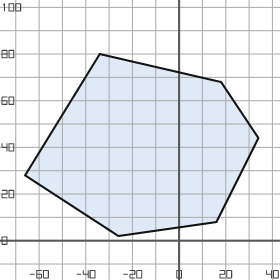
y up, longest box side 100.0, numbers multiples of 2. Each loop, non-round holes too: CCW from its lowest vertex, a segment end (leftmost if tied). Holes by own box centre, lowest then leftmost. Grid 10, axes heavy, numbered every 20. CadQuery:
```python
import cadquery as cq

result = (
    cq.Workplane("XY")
    .moveTo(-26.0, 2.0)
    .lineTo(16.0, 8.0)
    .lineTo(34.0, 44.0)
    .lineTo(18.0, 68.0)
    .lineTo(-34.0, 80.0)
    .lineTo(-66.0, 28.0)
    .close()
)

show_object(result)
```